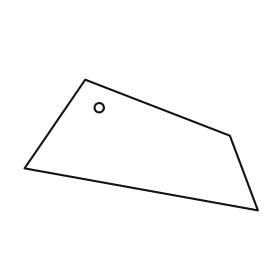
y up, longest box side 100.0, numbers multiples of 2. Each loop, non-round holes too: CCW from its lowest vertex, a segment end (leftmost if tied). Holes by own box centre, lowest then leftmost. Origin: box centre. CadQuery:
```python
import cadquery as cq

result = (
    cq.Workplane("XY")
    .moveTo(50.0, -28.0)
    .lineTo(38.0, 4.0)
    .lineTo(-24.0, 28.0)
    .lineTo(-50.0, -10.0)
    .close()
    .moveTo(-18.0, 16.0)
    .circle(2.0)
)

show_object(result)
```